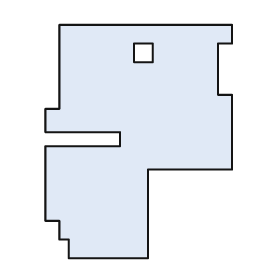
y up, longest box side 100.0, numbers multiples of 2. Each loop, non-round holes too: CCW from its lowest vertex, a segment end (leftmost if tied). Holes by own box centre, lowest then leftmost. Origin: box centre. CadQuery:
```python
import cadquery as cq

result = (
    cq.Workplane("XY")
    .moveTo(-30.0, -50.0)
    .lineTo(4.0, -50.0)
    .lineTo(4.0, -12.0)
    .lineTo(40.0, -12.0)
    .lineTo(40.0, 20.0)
    .lineTo(34.0, 20.0)
    .lineTo(34.0, 42.0)
    .lineTo(40.0, 42.0)
    .lineTo(40.0, 50.0)
    .lineTo(-34.0, 50.0)
    .lineTo(-34.0, 14.0)
    .lineTo(-40.0, 14.0)
    .lineTo(-40.0, 4.0)
    .lineTo(-8.0, 4.0)
    .lineTo(-8.0, -2.0)
    .lineTo(-40.0, -2.0)
    .lineTo(-40.0, -34.0)
    .lineTo(-34.0, -34.0)
    .lineTo(-34.0, -42.0)
    .lineTo(-30.0, -42.0)
    .close()
    .moveTo(-2.0, 34.0)
    .lineTo(6.0, 34.0)
    .lineTo(6.0, 42.0)
    .lineTo(-2.0, 42.0)
    .close()
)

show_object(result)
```